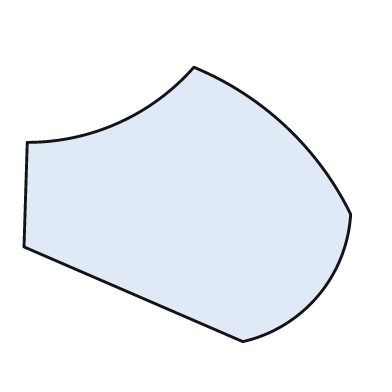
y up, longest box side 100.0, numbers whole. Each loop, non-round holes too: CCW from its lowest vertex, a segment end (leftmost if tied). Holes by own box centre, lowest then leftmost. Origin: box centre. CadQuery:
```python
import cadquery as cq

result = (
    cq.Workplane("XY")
    .moveTo(17.0, -42.0)
    .threePointArc((40.0, -28.0), (50.0, -3.0))
    .threePointArc((30.0, 24.0), (2.0, 42.0))
    .threePointArc((-21.0, 25.0), (-49.0, 19.0))
    .lineTo(-50.0, -13.0)
    .close()
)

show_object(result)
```